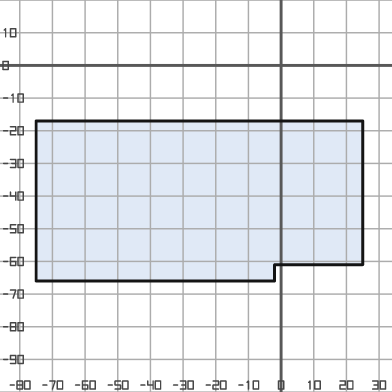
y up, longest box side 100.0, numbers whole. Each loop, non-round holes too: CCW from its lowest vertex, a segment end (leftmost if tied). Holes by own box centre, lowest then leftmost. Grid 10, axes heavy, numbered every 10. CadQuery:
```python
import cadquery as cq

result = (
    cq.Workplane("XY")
    .moveTo(-75.0, -66.0)
    .lineTo(-2.0, -66.0)
    .lineTo(-2.0, -61.0)
    .lineTo(25.0, -61.0)
    .lineTo(25.0, -17.0)
    .lineTo(-75.0, -17.0)
    .close()
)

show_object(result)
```